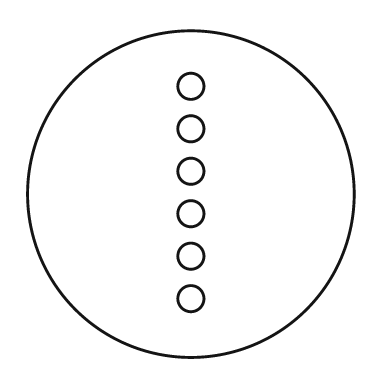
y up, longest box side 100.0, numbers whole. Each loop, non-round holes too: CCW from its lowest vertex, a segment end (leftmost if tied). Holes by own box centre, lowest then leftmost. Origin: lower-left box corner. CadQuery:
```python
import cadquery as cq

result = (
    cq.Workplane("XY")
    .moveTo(50.0, 50.0)
    .circle(50.0)
    .moveTo(50.0, 18.0)
    .circle(4.0)
    .moveTo(50.0, 31.0)
    .circle(4.0)
    .moveTo(50.0, 44.0)
    .circle(4.0)
    .moveTo(50.0, 57.0)
    .circle(4.0)
    .moveTo(50.0, 70.0)
    .circle(4.0)
    .moveTo(50.0, 83.0)
    .circle(4.0)
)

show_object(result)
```